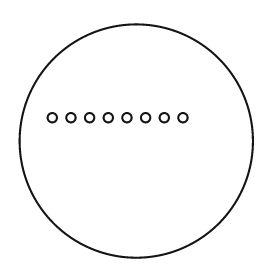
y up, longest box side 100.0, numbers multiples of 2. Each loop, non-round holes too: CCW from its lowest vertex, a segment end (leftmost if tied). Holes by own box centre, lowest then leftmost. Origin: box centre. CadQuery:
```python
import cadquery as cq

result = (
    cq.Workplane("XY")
    .moveTo(0.0, 0.0)
    .circle(50.0)
    .moveTo(-36.0, 10.0)
    .circle(2.0)
    .moveTo(-28.0, 10.0)
    .circle(2.0)
    .moveTo(-20.0, 10.0)
    .circle(2.0)
    .moveTo(-12.0, 10.0)
    .circle(2.0)
    .moveTo(-4.0, 10.0)
    .circle(2.0)
    .moveTo(4.0, 10.0)
    .circle(2.0)
    .moveTo(12.0, 10.0)
    .circle(2.0)
    .moveTo(20.0, 10.0)
    .circle(2.0)
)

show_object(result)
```